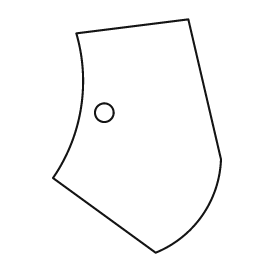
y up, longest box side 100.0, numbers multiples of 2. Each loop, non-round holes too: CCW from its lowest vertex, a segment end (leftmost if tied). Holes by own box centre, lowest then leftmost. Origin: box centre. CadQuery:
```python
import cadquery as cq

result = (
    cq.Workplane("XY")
    .moveTo(8.0, -50.0)
    .threePointArc((28.0, -34.0), (36.0, -10.0))
    .lineTo(22.0, 50.0)
    .lineTo(-26.0, 44.0)
    .threePointArc((-24.0, 12.0), (-36.0, -18.0))
    .close()
    .moveTo(-14.0, 10.0)
    .circle(4.0)
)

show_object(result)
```